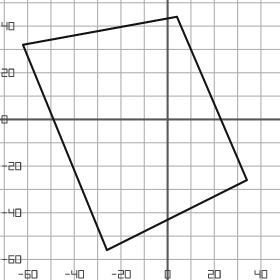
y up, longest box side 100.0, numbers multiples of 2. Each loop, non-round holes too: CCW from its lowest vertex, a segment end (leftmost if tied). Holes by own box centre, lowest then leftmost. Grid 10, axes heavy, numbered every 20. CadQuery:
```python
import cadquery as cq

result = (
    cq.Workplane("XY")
    .moveTo(-26.0, -56.0)
    .lineTo(34.0, -26.0)
    .lineTo(4.0, 44.0)
    .lineTo(-62.0, 32.0)
    .close()
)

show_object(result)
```